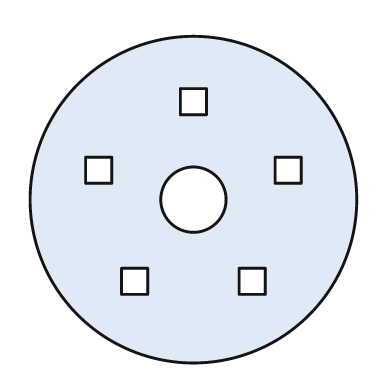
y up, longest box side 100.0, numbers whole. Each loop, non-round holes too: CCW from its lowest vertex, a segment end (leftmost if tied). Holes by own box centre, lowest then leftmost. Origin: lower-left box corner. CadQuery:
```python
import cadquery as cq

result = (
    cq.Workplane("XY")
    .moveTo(50.0, 50.0)
    .circle(50.0)
    .moveTo(28.0, 21.0)
    .lineTo(36.0, 21.0)
    .lineTo(36.0, 29.0)
    .lineTo(28.0, 29.0)
    .close()
    .moveTo(64.0, 21.0)
    .lineTo(72.0, 21.0)
    .lineTo(72.0, 29.0)
    .lineTo(64.0, 29.0)
    .close()
    .moveTo(50.0, 50.0)
    .circle(10.0)
    .moveTo(17.0, 55.0)
    .lineTo(25.0, 55.0)
    .lineTo(25.0, 63.0)
    .lineTo(17.0, 63.0)
    .close()
    .moveTo(75.0, 55.0)
    .lineTo(83.0, 55.0)
    .lineTo(83.0, 63.0)
    .lineTo(75.0, 63.0)
    .close()
    .moveTo(46.0, 76.0)
    .lineTo(54.0, 76.0)
    .lineTo(54.0, 84.0)
    .lineTo(46.0, 84.0)
    .close()
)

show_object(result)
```